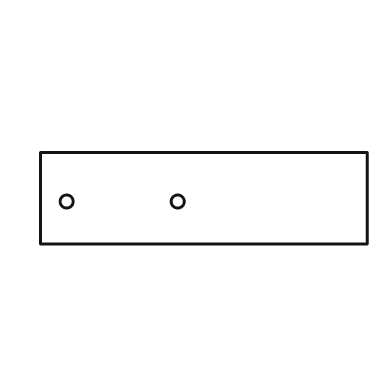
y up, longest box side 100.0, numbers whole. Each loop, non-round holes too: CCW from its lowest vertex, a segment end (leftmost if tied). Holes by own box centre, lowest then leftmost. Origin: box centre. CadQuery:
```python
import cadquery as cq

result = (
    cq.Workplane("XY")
    .moveTo(-50.0, -14.0)
    .lineTo(50.0, -14.0)
    .lineTo(50.0, 14.0)
    .lineTo(-50.0, 14.0)
    .close()
    .moveTo(-42.0, -1.0)
    .circle(2.0)
    .moveTo(-8.0, -1.0)
    .circle(2.0)
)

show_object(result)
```